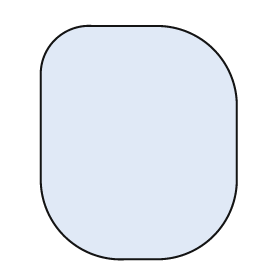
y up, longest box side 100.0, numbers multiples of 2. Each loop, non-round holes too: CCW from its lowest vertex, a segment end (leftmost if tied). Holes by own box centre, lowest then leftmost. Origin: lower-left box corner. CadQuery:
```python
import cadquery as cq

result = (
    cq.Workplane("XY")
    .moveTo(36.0, 0.0)
    .lineTo(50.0, 0.0)
    .threePointArc((74.0, 10.0), (84.0, 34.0))
    .lineTo(84.0, 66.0)
    .threePointArc((74.0, 90.0), (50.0, 100.0))
    .lineTo(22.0, 100.0)
    .threePointArc((6.0, 94.0), (0.0, 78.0))
    .lineTo(0.0, 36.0)
    .threePointArc((10.0, 10.0), (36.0, 0.0))
    .close()
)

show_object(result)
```